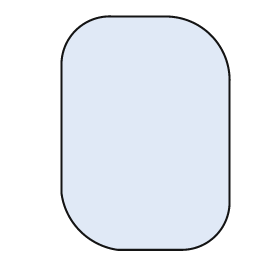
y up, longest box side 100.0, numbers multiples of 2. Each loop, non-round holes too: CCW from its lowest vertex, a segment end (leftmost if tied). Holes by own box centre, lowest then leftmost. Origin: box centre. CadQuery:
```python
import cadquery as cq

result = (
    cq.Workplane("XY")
    .moveTo(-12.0, -50.0)
    .lineTo(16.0, -50.0)
    .threePointArc((30.0, -44.0), (36.0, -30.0))
    .lineTo(36.0, 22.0)
    .threePointArc((28.0, 42.0), (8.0, 50.0))
    .lineTo(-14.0, 50.0)
    .threePointArc((-30.0, 44.0), (-36.0, 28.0))
    .lineTo(-36.0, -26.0)
    .threePointArc((-28.0, -42.0), (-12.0, -50.0))
    .close()
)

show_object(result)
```